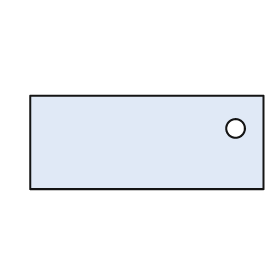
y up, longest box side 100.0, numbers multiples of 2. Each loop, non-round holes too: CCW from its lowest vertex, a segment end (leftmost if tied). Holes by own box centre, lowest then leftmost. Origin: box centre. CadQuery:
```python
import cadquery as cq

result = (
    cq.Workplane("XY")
    .moveTo(-50.0, -20.0)
    .lineTo(50.0, -20.0)
    .lineTo(50.0, 20.0)
    .lineTo(-50.0, 20.0)
    .close()
    .moveTo(38.0, 6.0)
    .circle(4.0)
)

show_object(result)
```